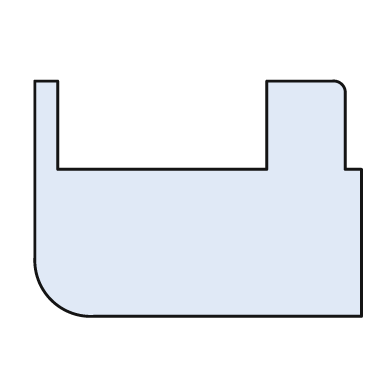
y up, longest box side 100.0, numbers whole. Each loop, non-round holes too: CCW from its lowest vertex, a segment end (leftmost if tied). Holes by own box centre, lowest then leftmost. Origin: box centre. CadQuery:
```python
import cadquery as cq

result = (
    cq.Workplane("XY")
    .moveTo(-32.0, -36.0)
    .lineTo(50.0, -36.0)
    .lineTo(50.0, 9.0)
    .lineTo(45.0, 9.0)
    .lineTo(45.0, 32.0)
    .threePointArc((44.0, 35.0), (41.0, 36.0))
    .lineTo(21.0, 36.0)
    .lineTo(21.0, 9.0)
    .lineTo(-43.0, 9.0)
    .lineTo(-43.0, 36.0)
    .lineTo(-50.0, 36.0)
    .lineTo(-50.0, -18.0)
    .threePointArc((-45.0, -31.0), (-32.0, -36.0))
    .close()
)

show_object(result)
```